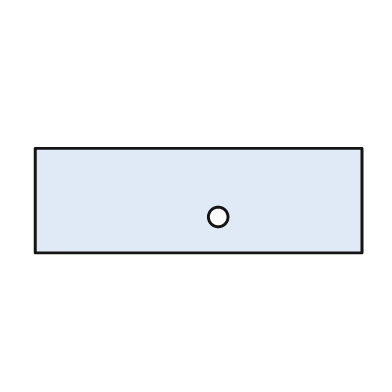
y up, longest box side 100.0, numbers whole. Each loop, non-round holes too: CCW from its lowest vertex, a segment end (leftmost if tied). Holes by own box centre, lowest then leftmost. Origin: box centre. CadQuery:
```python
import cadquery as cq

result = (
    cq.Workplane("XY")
    .moveTo(-50.0, -16.0)
    .lineTo(50.0, -16.0)
    .lineTo(50.0, 16.0)
    .lineTo(-50.0, 16.0)
    .close()
    .moveTo(6.0, -5.0)
    .circle(3.0)
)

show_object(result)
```